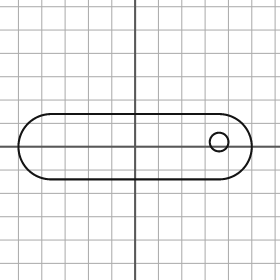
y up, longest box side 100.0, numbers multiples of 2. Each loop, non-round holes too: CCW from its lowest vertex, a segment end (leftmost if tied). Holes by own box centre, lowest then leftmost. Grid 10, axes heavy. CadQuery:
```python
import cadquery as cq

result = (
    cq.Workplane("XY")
    .moveTo(-36.0, -14.0)
    .lineTo(36.0, -14.0)
    .threePointArc((50.0, 0.0), (36.0, 14.0))
    .lineTo(-36.0, 14.0)
    .threePointArc((-50.0, 0.0), (-36.0, -14.0))
    .close()
    .moveTo(36.0, 2.0)
    .circle(4.0)
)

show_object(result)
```